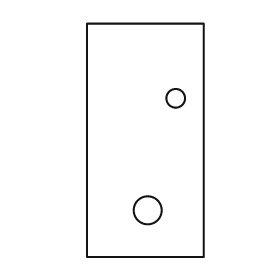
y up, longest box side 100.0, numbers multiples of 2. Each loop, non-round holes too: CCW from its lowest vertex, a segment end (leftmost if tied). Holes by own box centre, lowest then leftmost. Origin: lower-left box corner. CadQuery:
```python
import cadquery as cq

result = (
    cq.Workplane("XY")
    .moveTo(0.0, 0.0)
    .lineTo(50.0, 0.0)
    .lineTo(50.0, 100.0)
    .lineTo(0.0, 100.0)
    .close()
    .moveTo(26.0, 20.0)
    .circle(6.0)
    .moveTo(38.0, 68.0)
    .circle(4.0)
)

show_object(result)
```